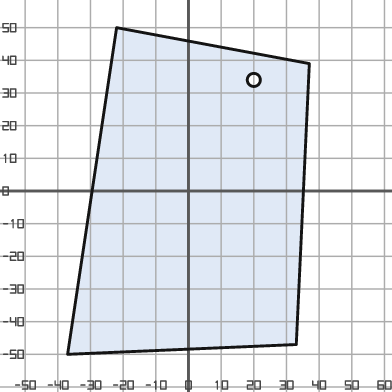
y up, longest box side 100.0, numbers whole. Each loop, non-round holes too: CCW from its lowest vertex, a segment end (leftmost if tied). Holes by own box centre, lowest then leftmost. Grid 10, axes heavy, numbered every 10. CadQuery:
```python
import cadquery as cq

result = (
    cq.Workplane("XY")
    .moveTo(-37.0, -50.0)
    .lineTo(33.0, -47.0)
    .lineTo(37.0, 39.0)
    .lineTo(-22.0, 50.0)
    .close()
    .moveTo(20.0, 34.0)
    .circle(2.0)
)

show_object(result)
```